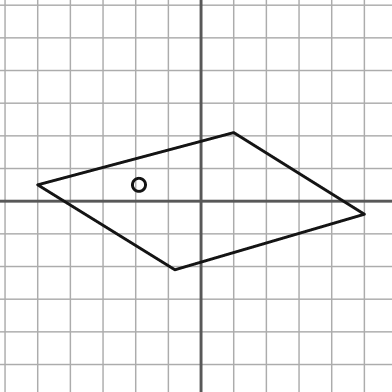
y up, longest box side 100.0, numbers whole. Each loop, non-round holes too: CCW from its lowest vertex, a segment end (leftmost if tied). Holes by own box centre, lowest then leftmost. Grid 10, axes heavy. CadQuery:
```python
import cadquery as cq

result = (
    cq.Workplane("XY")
    .moveTo(-8.0, -21.0)
    .lineTo(50.0, -4.0)
    .lineTo(10.0, 21.0)
    .lineTo(-50.0, 5.0)
    .close()
    .moveTo(-19.0, 5.0)
    .circle(2.0)
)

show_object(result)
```